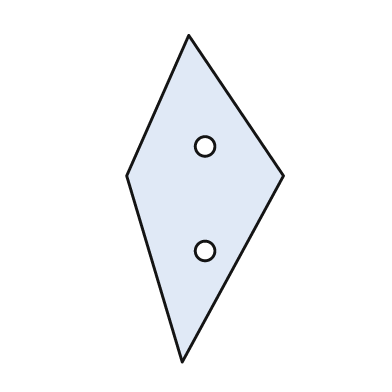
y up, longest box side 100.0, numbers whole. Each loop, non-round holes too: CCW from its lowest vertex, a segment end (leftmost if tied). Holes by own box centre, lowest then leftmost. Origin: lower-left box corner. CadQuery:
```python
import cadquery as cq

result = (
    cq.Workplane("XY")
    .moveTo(17.0, 0.0)
    .lineTo(48.0, 57.0)
    .lineTo(19.0, 100.0)
    .lineTo(0.0, 57.0)
    .close()
    .moveTo(24.0, 34.0)
    .circle(3.0)
    .moveTo(24.0, 66.0)
    .circle(3.0)
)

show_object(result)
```